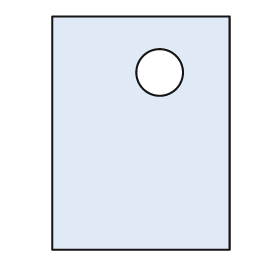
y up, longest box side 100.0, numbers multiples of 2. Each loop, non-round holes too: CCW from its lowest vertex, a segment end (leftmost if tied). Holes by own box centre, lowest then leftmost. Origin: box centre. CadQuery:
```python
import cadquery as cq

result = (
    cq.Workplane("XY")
    .moveTo(-38.0, -50.0)
    .lineTo(38.0, -50.0)
    .lineTo(38.0, 50.0)
    .lineTo(-38.0, 50.0)
    .close()
    .moveTo(8.0, 26.0)
    .circle(10.0)
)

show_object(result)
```